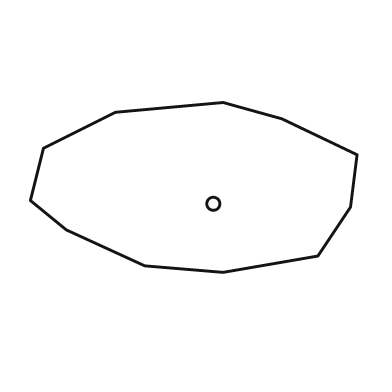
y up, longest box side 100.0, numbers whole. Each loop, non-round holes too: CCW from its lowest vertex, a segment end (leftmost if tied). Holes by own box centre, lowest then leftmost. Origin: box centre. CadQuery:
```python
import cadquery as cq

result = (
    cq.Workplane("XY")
    .moveTo(9.0, -26.0)
    .lineTo(38.0, -21.0)
    .lineTo(48.0, -6.0)
    .lineTo(50.0, 10.0)
    .lineTo(27.0, 21.0)
    .lineTo(9.0, 26.0)
    .lineTo(-24.0, 23.0)
    .lineTo(-46.0, 12.0)
    .lineTo(-50.0, -4.0)
    .lineTo(-39.0, -13.0)
    .lineTo(-15.0, -24.0)
    .close()
    .moveTo(6.0, -5.0)
    .circle(2.0)
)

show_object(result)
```